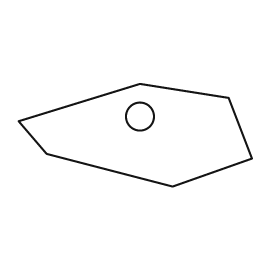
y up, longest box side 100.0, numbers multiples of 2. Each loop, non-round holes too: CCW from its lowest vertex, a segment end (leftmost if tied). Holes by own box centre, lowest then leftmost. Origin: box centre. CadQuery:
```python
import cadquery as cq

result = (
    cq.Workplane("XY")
    .moveTo(16.0, -22.0)
    .lineTo(50.0, -10.0)
    .lineTo(40.0, 16.0)
    .lineTo(2.0, 22.0)
    .lineTo(-50.0, 6.0)
    .lineTo(-38.0, -8.0)
    .close()
    .moveTo(2.0, 8.0)
    .circle(6.0)
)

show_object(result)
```